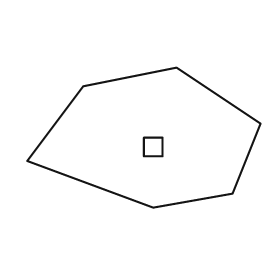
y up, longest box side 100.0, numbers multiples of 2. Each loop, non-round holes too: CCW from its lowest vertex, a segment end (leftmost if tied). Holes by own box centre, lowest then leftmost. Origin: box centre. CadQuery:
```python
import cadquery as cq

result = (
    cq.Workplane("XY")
    .moveTo(4.0, -30.0)
    .lineTo(38.0, -24.0)
    .lineTo(50.0, 6.0)
    .lineTo(14.0, 30.0)
    .lineTo(-26.0, 22.0)
    .lineTo(-50.0, -10.0)
    .close()
    .moveTo(0.0, -8.0)
    .lineTo(8.0, -8.0)
    .lineTo(8.0, 0.0)
    .lineTo(0.0, 0.0)
    .close()
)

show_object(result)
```